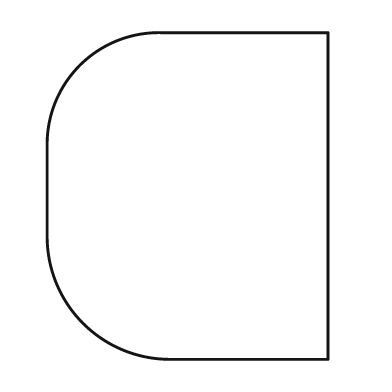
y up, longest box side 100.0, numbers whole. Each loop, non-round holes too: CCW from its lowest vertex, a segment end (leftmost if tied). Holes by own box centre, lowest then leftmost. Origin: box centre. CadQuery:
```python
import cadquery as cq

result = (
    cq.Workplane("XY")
    .moveTo(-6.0, -50.0)
    .lineTo(43.0, -50.0)
    .lineTo(43.0, 50.0)
    .lineTo(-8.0, 50.0)
    .threePointArc((-33.0, 40.0), (-43.0, 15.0))
    .lineTo(-43.0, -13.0)
    .threePointArc((-32.0, -39.0), (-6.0, -50.0))
    .close()
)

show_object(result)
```